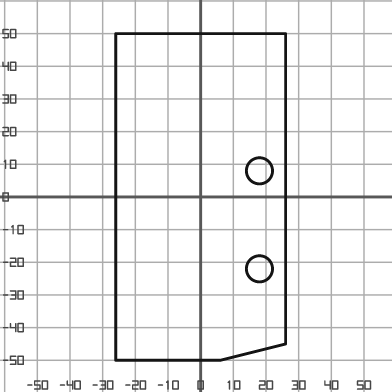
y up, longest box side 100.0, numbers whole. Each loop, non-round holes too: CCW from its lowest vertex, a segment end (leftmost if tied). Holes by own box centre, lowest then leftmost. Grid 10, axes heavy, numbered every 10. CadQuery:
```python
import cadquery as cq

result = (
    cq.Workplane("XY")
    .moveTo(-26.0, -50.0)
    .lineTo(6.0, -50.0)
    .lineTo(26.0, -45.0)
    .lineTo(26.0, 50.0)
    .lineTo(-26.0, 50.0)
    .close()
    .moveTo(18.0, -22.0)
    .circle(4.0)
    .moveTo(18.0, 8.0)
    .circle(4.0)
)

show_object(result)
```